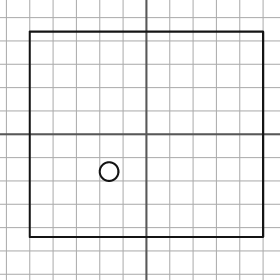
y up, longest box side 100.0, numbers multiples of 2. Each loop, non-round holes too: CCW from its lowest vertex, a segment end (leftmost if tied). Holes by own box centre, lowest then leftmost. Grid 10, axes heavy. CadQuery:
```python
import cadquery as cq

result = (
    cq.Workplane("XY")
    .moveTo(-50.0, -44.0)
    .lineTo(50.0, -44.0)
    .lineTo(50.0, 44.0)
    .lineTo(-50.0, 44.0)
    .close()
    .moveTo(-16.0, -16.0)
    .circle(4.0)
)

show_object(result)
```